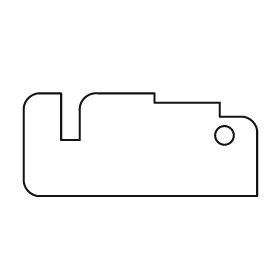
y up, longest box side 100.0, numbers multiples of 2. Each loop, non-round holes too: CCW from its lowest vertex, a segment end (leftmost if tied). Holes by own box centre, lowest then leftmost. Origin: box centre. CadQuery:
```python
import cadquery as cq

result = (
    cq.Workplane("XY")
    .moveTo(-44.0, -22.0)
    .lineTo(50.0, -22.0)
    .lineTo(50.0, 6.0)
    .threePointArc((48.0, 10.0), (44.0, 12.0))
    .lineTo(34.0, 12.0)
    .lineTo(34.0, 18.0)
    .lineTo(6.0, 18.0)
    .lineTo(6.0, 22.0)
    .lineTo(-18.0, 22.0)
    .threePointArc((-24.0, 20.0), (-26.0, 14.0))
    .lineTo(-26.0, 2.0)
    .lineTo(-34.0, 2.0)
    .lineTo(-34.0, 22.0)
    .lineTo(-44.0, 22.0)
    .threePointArc((-48.0, 20.0), (-50.0, 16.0))
    .lineTo(-50.0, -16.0)
    .threePointArc((-48.0, -20.0), (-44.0, -22.0))
    .close()
    .moveTo(36.0, 4.0)
    .circle(4.0)
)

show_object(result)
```